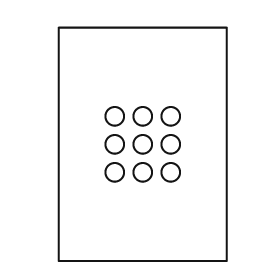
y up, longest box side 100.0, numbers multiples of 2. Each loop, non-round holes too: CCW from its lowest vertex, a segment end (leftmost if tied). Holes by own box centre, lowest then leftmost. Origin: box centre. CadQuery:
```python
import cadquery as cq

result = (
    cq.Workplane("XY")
    .moveTo(-36.0, -50.0)
    .lineTo(36.0, -50.0)
    .lineTo(36.0, 50.0)
    .lineTo(-36.0, 50.0)
    .close()
    .moveTo(-12.0, -12.0)
    .circle(4.0)
    .moveTo(0.0, -12.0)
    .circle(4.0)
    .moveTo(12.0, -12.0)
    .circle(4.0)
    .moveTo(-12.0, 0.0)
    .circle(4.0)
    .moveTo(0.0, 0.0)
    .circle(4.0)
    .moveTo(12.0, 0.0)
    .circle(4.0)
    .moveTo(-12.0, 12.0)
    .circle(4.0)
    .moveTo(0.0, 12.0)
    .circle(4.0)
    .moveTo(12.0, 12.0)
    .circle(4.0)
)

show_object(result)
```